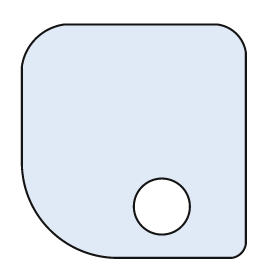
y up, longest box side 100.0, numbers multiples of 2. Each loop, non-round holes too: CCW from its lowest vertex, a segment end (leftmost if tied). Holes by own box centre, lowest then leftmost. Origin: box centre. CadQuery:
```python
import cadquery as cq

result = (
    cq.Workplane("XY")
    .moveTo(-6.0, -50.0)
    .lineTo(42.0, -50.0)
    .threePointArc((46.0, -48.0), (48.0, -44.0))
    .lineTo(48.0, 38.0)
    .threePointArc((44.0, 46.0), (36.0, 50.0))
    .lineTo(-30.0, 50.0)
    .threePointArc((-42.0, 44.0), (-48.0, 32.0))
    .lineTo(-48.0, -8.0)
    .threePointArc((-36.0, -38.0), (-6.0, -50.0))
    .close()
    .moveTo(12.0, -28.0)
    .circle(12.0)
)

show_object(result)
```